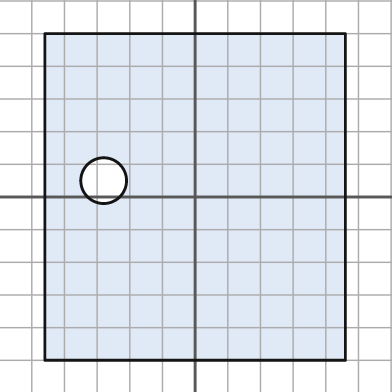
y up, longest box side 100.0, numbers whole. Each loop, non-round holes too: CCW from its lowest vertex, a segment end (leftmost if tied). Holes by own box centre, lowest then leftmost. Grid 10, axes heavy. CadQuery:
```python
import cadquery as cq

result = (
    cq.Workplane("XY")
    .moveTo(-46.0, -50.0)
    .lineTo(46.0, -50.0)
    .lineTo(46.0, 50.0)
    .lineTo(-46.0, 50.0)
    .close()
    .moveTo(-28.0, 5.0)
    .circle(7.0)
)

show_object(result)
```